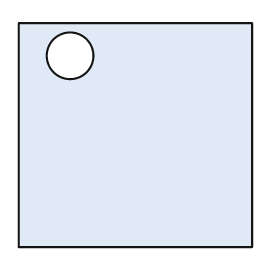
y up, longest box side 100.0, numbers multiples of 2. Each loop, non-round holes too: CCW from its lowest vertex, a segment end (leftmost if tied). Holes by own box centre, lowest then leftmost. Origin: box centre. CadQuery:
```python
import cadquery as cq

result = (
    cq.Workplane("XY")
    .moveTo(-50.0, -48.0)
    .lineTo(50.0, -48.0)
    .lineTo(50.0, 48.0)
    .lineTo(-50.0, 48.0)
    .close()
    .moveTo(-28.0, 34.0)
    .circle(10.0)
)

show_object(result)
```